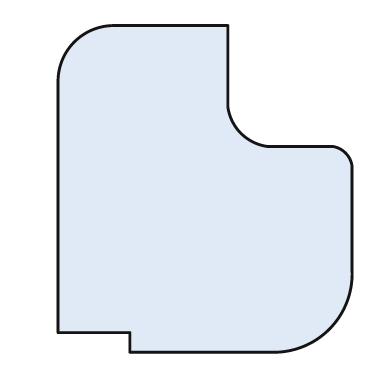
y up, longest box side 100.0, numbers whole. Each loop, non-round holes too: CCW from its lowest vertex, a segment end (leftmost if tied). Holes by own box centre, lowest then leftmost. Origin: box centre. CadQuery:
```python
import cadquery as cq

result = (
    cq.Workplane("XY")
    .moveTo(-23.0, -50.0)
    .lineTo(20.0, -50.0)
    .threePointArc((38.0, -43.0), (45.0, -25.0))
    .lineTo(45.0, 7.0)
    .threePointArc((43.0, 11.0), (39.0, 13.0))
    .lineTo(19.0, 13.0)
    .threePointArc((11.0, 17.0), (7.0, 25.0))
    .lineTo(7.0, 50.0)
    .lineTo(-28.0, 50.0)
    .threePointArc((-40.0, 45.0), (-45.0, 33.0))
    .lineTo(-45.0, -44.0)
    .lineTo(-23.0, -44.0)
    .close()
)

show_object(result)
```